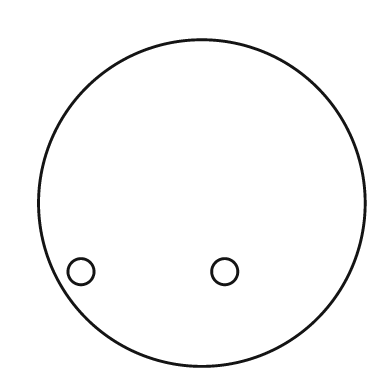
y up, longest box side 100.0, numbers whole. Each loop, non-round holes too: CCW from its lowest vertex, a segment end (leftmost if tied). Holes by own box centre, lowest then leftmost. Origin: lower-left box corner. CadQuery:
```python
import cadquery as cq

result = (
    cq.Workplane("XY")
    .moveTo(50.0, 50.0)
    .circle(50.0)
    .moveTo(13.0, 29.0)
    .circle(4.0)
    .moveTo(57.0, 29.0)
    .circle(4.0)
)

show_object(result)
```